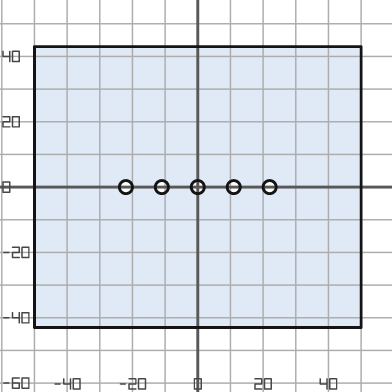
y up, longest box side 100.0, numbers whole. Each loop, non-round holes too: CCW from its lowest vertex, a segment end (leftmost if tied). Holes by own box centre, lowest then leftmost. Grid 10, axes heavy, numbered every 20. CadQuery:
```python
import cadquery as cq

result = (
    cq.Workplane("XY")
    .moveTo(-50.0, -43.0)
    .lineTo(50.0, -43.0)
    .lineTo(50.0, 43.0)
    .lineTo(-50.0, 43.0)
    .close()
    .moveTo(-22.0, 0.0)
    .circle(2.0)
    .moveTo(-11.0, 0.0)
    .circle(2.0)
    .moveTo(0.0, 0.0)
    .circle(2.0)
    .moveTo(11.0, 0.0)
    .circle(2.0)
    .moveTo(22.0, 0.0)
    .circle(2.0)
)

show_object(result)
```